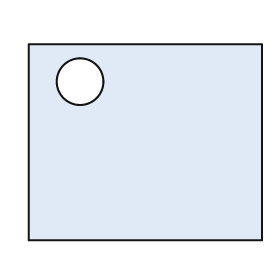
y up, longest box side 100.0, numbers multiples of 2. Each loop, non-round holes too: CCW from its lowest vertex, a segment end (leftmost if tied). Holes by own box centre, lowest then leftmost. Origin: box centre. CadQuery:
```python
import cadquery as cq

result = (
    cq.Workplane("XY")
    .moveTo(-50.0, -42.0)
    .lineTo(50.0, -42.0)
    .lineTo(50.0, 42.0)
    .lineTo(-50.0, 42.0)
    .close()
    .moveTo(-28.0, 26.0)
    .circle(10.0)
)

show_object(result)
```